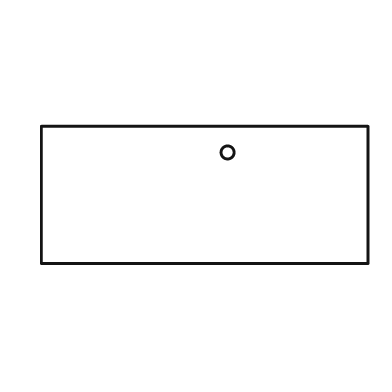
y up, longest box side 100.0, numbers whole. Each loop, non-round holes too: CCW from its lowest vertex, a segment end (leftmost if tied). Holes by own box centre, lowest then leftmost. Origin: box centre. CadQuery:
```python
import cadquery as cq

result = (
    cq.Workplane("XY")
    .moveTo(-50.0, -21.0)
    .lineTo(50.0, -21.0)
    .lineTo(50.0, 21.0)
    .lineTo(-50.0, 21.0)
    .close()
    .moveTo(7.0, 13.0)
    .circle(2.0)
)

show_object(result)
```